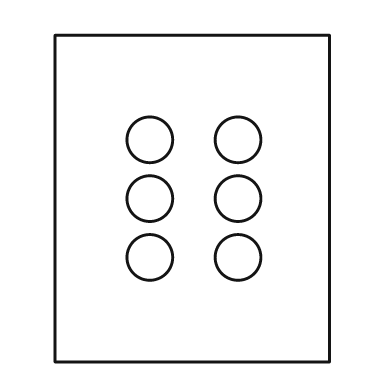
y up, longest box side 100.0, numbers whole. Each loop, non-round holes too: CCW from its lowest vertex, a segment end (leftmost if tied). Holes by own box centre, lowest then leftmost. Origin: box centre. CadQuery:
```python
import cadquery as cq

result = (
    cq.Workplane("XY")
    .moveTo(-42.0, -50.0)
    .lineTo(42.0, -50.0)
    .lineTo(42.0, 50.0)
    .lineTo(-42.0, 50.0)
    .close()
    .moveTo(-13.0, -18.0)
    .circle(7.0)
    .moveTo(14.0, -18.0)
    .circle(7.0)
    .moveTo(-13.0, 0.0)
    .circle(7.0)
    .moveTo(14.0, 0.0)
    .circle(7.0)
    .moveTo(-13.0, 18.0)
    .circle(7.0)
    .moveTo(14.0, 18.0)
    .circle(7.0)
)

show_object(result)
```